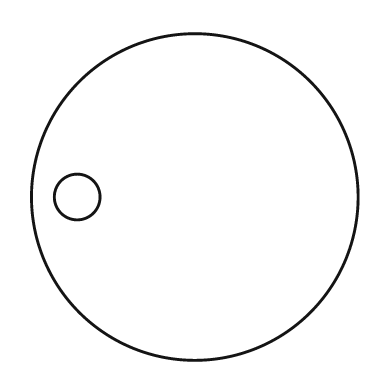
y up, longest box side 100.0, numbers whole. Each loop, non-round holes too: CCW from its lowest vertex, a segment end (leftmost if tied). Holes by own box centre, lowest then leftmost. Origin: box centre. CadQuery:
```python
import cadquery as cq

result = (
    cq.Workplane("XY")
    .moveTo(0.0, 0.0)
    .circle(50.0)
    .moveTo(-36.0, 0.0)
    .circle(7.0)
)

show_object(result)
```